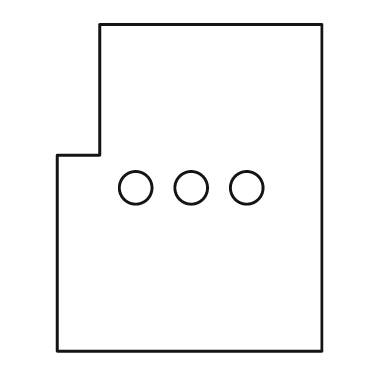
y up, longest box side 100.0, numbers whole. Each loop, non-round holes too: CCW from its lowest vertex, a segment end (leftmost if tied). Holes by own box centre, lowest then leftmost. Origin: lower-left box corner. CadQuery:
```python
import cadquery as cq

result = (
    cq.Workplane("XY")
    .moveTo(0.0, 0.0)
    .lineTo(81.0, 0.0)
    .lineTo(81.0, 100.0)
    .lineTo(13.0, 100.0)
    .lineTo(13.0, 60.0)
    .lineTo(0.0, 60.0)
    .close()
    .moveTo(24.0, 50.0)
    .circle(5.0)
    .moveTo(41.0, 50.0)
    .circle(5.0)
    .moveTo(58.0, 50.0)
    .circle(5.0)
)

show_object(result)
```